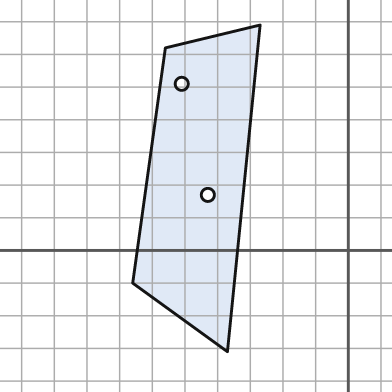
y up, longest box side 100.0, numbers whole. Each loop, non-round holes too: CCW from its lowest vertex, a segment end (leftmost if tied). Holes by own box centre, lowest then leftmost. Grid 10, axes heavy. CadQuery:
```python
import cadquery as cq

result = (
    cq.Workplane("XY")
    .moveTo(-37.0, -31.0)
    .lineTo(-27.0, 69.0)
    .lineTo(-56.0, 62.0)
    .lineTo(-66.0, -10.0)
    .close()
    .moveTo(-43.0, 17.0)
    .circle(2.0)
    .moveTo(-51.0, 51.0)
    .circle(2.0)
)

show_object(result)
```